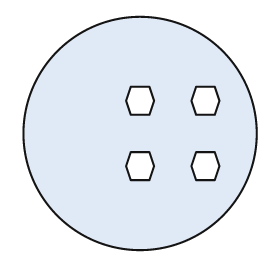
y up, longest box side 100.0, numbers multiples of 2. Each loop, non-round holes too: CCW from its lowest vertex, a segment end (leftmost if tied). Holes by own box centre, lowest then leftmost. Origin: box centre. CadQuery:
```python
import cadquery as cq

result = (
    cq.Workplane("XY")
    .moveTo(0.0, 0.0)
    .circle(50.0)
    .moveTo(-4.0, -20.0)
    .lineTo(4.0, -20.0)
    .lineTo(6.0, -14.0)
    .lineTo(4.0, -8.0)
    .lineTo(-4.0, -8.0)
    .lineTo(-6.0, -14.0)
    .close()
    .moveTo(24.0, -20.0)
    .lineTo(32.0, -20.0)
    .lineTo(34.0, -14.0)
    .lineTo(32.0, -8.0)
    .lineTo(24.0, -8.0)
    .lineTo(22.0, -14.0)
    .close()
    .moveTo(-4.0, 8.0)
    .lineTo(4.0, 8.0)
    .lineTo(6.0, 14.0)
    .lineTo(4.0, 20.0)
    .lineTo(-4.0, 20.0)
    .lineTo(-6.0, 14.0)
    .close()
    .moveTo(24.0, 8.0)
    .lineTo(32.0, 8.0)
    .lineTo(34.0, 14.0)
    .lineTo(32.0, 20.0)
    .lineTo(24.0, 20.0)
    .lineTo(22.0, 14.0)
    .close()
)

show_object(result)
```